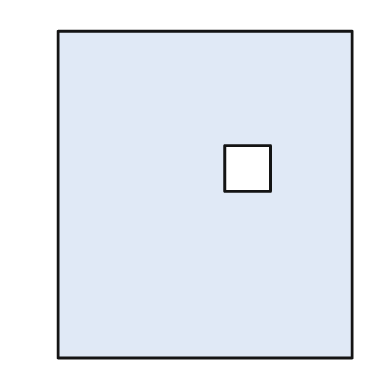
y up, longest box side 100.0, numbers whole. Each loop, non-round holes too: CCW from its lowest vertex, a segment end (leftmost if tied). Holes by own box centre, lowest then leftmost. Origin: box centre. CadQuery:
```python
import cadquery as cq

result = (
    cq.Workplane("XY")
    .moveTo(-45.0, -50.0)
    .lineTo(45.0, -50.0)
    .lineTo(45.0, 50.0)
    .lineTo(-45.0, 50.0)
    .close()
    .moveTo(6.0, 1.0)
    .lineTo(20.0, 1.0)
    .lineTo(20.0, 15.0)
    .lineTo(6.0, 15.0)
    .close()
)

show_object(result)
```